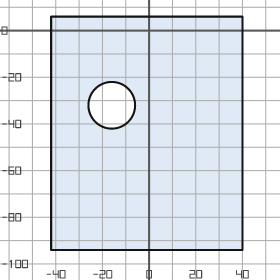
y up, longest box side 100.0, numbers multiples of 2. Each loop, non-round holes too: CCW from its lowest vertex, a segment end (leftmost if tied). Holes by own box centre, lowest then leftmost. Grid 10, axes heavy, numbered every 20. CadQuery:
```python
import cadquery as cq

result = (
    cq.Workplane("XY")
    .moveTo(-42.0, -94.0)
    .lineTo(40.0, -94.0)
    .lineTo(40.0, 6.0)
    .lineTo(-42.0, 6.0)
    .close()
    .moveTo(-16.0, -32.0)
    .circle(10.0)
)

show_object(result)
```